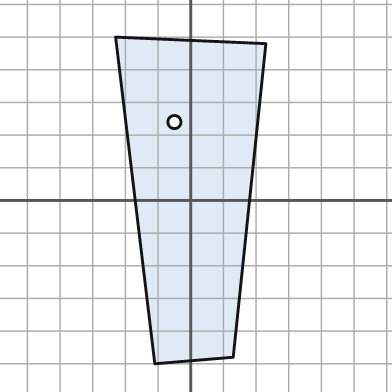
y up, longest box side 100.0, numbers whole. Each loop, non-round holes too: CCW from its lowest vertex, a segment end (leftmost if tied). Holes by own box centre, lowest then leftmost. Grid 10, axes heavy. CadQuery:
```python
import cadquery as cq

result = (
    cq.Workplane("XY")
    .moveTo(-11.0, -50.0)
    .lineTo(13.0, -48.0)
    .lineTo(23.0, 48.0)
    .lineTo(-23.0, 50.0)
    .close()
    .moveTo(-5.0, 24.0)
    .circle(2.0)
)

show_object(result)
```